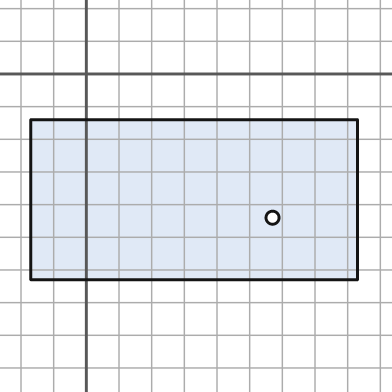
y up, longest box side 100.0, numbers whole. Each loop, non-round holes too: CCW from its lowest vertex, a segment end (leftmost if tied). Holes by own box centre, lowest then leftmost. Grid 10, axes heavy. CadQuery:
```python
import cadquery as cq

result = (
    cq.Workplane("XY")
    .moveTo(-17.0, -63.0)
    .lineTo(83.0, -63.0)
    .lineTo(83.0, -14.0)
    .lineTo(-17.0, -14.0)
    .close()
    .moveTo(57.0, -44.0)
    .circle(2.0)
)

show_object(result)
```